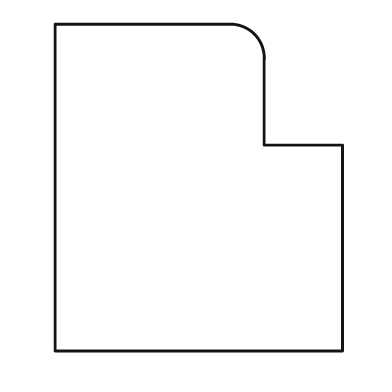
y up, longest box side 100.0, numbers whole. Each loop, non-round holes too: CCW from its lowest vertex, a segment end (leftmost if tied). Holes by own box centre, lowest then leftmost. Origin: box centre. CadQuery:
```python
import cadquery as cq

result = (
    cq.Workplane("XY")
    .moveTo(-44.0, -50.0)
    .lineTo(44.0, -50.0)
    .lineTo(44.0, 13.0)
    .lineTo(20.0, 13.0)
    .lineTo(20.0, 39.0)
    .threePointArc((17.0, 47.0), (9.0, 50.0))
    .lineTo(-44.0, 50.0)
    .close()
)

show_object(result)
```